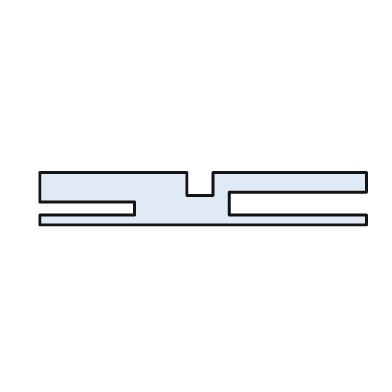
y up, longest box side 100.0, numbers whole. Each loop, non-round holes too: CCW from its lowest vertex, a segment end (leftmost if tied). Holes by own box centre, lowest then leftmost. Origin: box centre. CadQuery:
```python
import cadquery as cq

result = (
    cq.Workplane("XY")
    .moveTo(-50.0, -8.0)
    .lineTo(50.0, -8.0)
    .lineTo(50.0, -5.0)
    .lineTo(8.0, -5.0)
    .lineTo(8.0, 2.0)
    .lineTo(50.0, 2.0)
    .lineTo(50.0, 8.0)
    .lineTo(3.0, 8.0)
    .lineTo(3.0, 1.0)
    .lineTo(-5.0, 1.0)
    .lineTo(-5.0, 8.0)
    .lineTo(-50.0, 8.0)
    .lineTo(-50.0, -1.0)
    .lineTo(-21.0, -1.0)
    .lineTo(-21.0, -5.0)
    .lineTo(-50.0, -5.0)
    .close()
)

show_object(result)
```